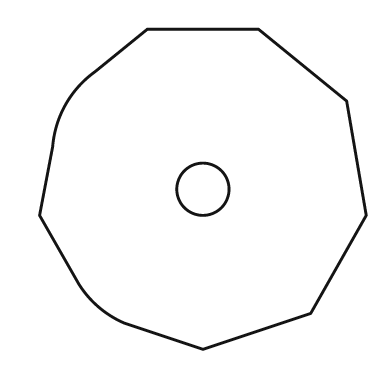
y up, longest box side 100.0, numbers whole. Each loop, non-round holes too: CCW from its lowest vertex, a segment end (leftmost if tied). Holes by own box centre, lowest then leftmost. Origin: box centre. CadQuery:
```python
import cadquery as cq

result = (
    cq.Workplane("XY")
    .moveTo(0.0, -49.0)
    .lineTo(33.0, -38.0)
    .lineTo(50.0, -8.0)
    .lineTo(44.0, 27.0)
    .lineTo(17.0, 49.0)
    .lineTo(-17.0, 49.0)
    .lineTo(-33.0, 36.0)
    .threePointArc((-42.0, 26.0), (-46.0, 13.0))
    .lineTo(-50.0, -8.0)
    .lineTo(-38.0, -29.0)
    .threePointArc((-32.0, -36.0), (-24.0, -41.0))
    .close()
    .moveTo(0.0, 0.0)
    .circle(8.0)
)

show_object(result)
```